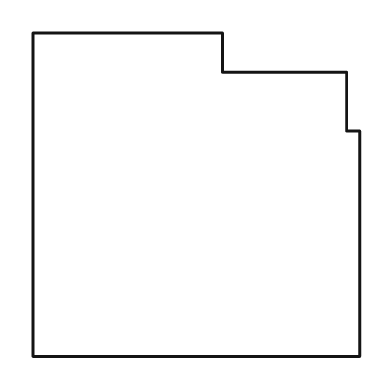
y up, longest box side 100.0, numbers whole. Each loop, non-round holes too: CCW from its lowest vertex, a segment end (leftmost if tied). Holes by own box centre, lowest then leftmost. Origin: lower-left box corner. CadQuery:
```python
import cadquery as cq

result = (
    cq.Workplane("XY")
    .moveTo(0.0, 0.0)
    .lineTo(100.0, 0.0)
    .lineTo(100.0, 69.0)
    .lineTo(96.0, 69.0)
    .lineTo(96.0, 87.0)
    .lineTo(58.0, 87.0)
    .lineTo(58.0, 99.0)
    .lineTo(0.0, 99.0)
    .close()
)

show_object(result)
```